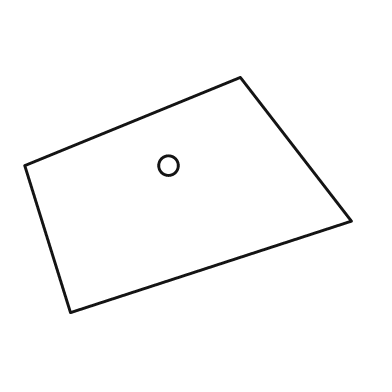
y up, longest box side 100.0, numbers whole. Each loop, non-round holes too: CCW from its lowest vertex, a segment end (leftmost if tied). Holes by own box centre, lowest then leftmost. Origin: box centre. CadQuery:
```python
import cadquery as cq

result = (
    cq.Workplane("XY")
    .moveTo(-36.0, -36.0)
    .lineTo(50.0, -8.0)
    .lineTo(16.0, 36.0)
    .lineTo(-50.0, 9.0)
    .close()
    .moveTo(-6.0, 9.0)
    .circle(3.0)
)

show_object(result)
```